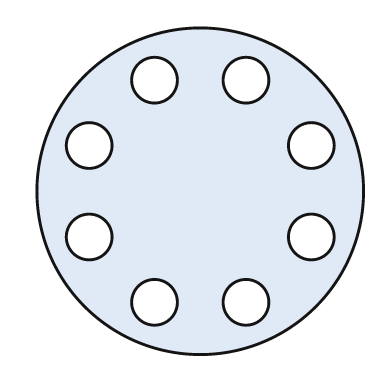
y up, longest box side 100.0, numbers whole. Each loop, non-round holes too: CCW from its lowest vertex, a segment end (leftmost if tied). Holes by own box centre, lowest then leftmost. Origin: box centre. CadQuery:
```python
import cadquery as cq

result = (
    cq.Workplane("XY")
    .moveTo(0.0, 0.0)
    .circle(50.0)
    .moveTo(-14.0, -34.0)
    .circle(7.0)
    .moveTo(14.0, -34.0)
    .circle(7.0)
    .moveTo(-34.0, -14.0)
    .circle(7.0)
    .moveTo(34.0, -14.0)
    .circle(7.0)
    .moveTo(-34.0, 14.0)
    .circle(7.0)
    .moveTo(34.0, 14.0)
    .circle(7.0)
    .moveTo(-14.0, 34.0)
    .circle(7.0)
    .moveTo(14.0, 34.0)
    .circle(7.0)
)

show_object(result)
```